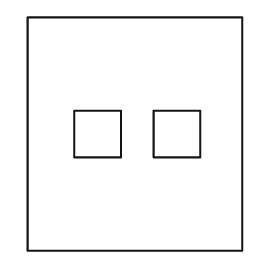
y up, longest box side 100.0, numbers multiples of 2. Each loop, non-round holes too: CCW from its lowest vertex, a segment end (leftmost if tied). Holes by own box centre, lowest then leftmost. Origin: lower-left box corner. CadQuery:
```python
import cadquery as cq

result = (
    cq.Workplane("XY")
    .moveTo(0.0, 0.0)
    .lineTo(92.0, 0.0)
    .lineTo(92.0, 100.0)
    .lineTo(0.0, 100.0)
    .close()
    .moveTo(20.0, 40.0)
    .lineTo(40.0, 40.0)
    .lineTo(40.0, 60.0)
    .lineTo(20.0, 60.0)
    .close()
    .moveTo(54.0, 40.0)
    .lineTo(74.0, 40.0)
    .lineTo(74.0, 60.0)
    .lineTo(54.0, 60.0)
    .close()
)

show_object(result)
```